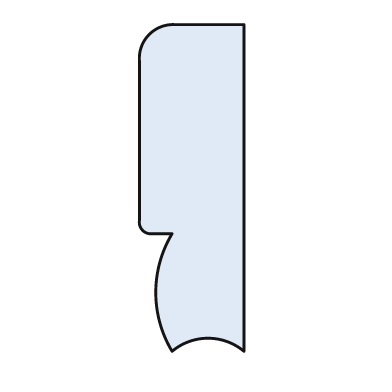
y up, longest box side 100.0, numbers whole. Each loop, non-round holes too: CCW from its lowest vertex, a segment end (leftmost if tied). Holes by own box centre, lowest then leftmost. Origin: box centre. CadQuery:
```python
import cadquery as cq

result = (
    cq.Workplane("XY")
    .moveTo(-6.0, -50.0)
    .threePointArc((5.0, -46.0), (16.0, -50.0))
    .lineTo(16.0, 50.0)
    .lineTo(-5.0, 50.0)
    .threePointArc((-13.0, 47.0), (-16.0, 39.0))
    .lineTo(-16.0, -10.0)
    .threePointArc((-15.0, -13.0), (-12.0, -14.0))
    .lineTo(-6.0, -14.0)
    .threePointArc((-11.0, -32.0), (-6.0, -50.0))
    .close()
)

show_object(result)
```